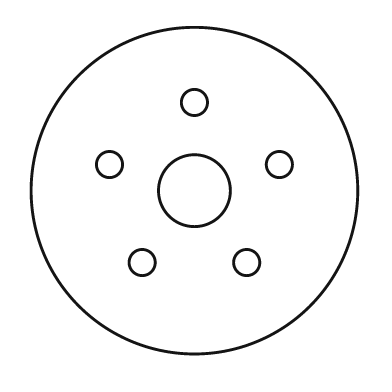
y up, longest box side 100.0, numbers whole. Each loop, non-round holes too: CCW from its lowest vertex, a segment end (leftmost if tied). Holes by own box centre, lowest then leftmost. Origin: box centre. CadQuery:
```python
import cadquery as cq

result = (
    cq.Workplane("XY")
    .moveTo(0.0, 0.0)
    .circle(50.0)
    .moveTo(-16.0, -22.0)
    .circle(4.0)
    .moveTo(16.0, -22.0)
    .circle(4.0)
    .moveTo(0.0, 0.0)
    .circle(11.0)
    .moveTo(-26.0, 8.0)
    .circle(4.0)
    .moveTo(26.0, 8.0)
    .circle(4.0)
    .moveTo(0.0, 27.0)
    .circle(4.0)
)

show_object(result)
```